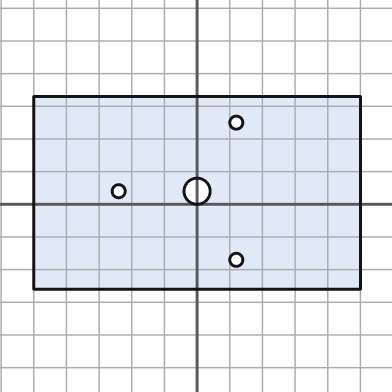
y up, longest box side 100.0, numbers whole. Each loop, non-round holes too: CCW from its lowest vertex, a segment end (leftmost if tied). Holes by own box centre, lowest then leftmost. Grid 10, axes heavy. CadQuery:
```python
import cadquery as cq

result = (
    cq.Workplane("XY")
    .moveTo(-50.0, -26.0)
    .lineTo(50.0, -26.0)
    .lineTo(50.0, 33.0)
    .lineTo(-50.0, 33.0)
    .close()
    .moveTo(12.0, -17.0)
    .circle(2.0)
    .moveTo(-24.0, 4.0)
    .circle(2.0)
    .moveTo(0.0, 4.0)
    .circle(4.0)
    .moveTo(12.0, 25.0)
    .circle(2.0)
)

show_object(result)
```